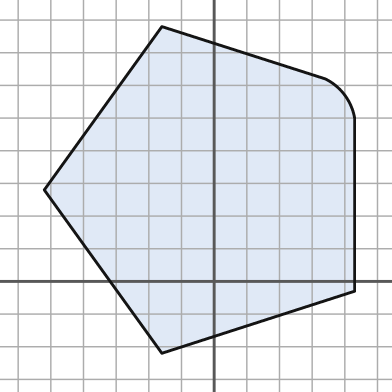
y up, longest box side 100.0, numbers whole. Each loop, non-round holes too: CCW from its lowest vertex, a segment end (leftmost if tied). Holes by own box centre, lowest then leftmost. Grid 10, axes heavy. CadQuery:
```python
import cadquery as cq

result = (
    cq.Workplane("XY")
    .moveTo(-16.0, -22.0)
    .lineTo(43.0, -3.0)
    .lineTo(43.0, 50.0)
    .threePointArc((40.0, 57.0), (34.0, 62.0))
    .lineTo(-16.0, 78.0)
    .lineTo(-52.0, 28.0)
    .close()
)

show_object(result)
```